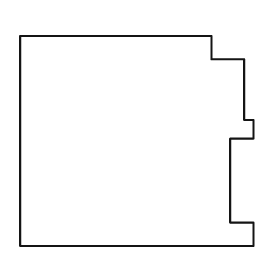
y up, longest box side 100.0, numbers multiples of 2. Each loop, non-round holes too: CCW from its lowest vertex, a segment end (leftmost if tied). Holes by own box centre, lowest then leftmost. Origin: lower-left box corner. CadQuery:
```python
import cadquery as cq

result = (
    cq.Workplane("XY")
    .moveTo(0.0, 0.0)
    .lineTo(100.0, 0.0)
    .lineTo(100.0, 10.0)
    .lineTo(90.0, 10.0)
    .lineTo(90.0, 46.0)
    .lineTo(100.0, 46.0)
    .lineTo(100.0, 54.0)
    .lineTo(96.0, 54.0)
    .lineTo(96.0, 80.0)
    .lineTo(82.0, 80.0)
    .lineTo(82.0, 90.0)
    .lineTo(0.0, 90.0)
    .close()
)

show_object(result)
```